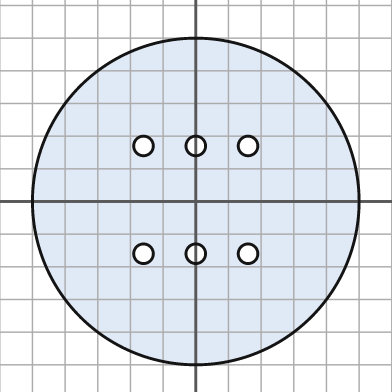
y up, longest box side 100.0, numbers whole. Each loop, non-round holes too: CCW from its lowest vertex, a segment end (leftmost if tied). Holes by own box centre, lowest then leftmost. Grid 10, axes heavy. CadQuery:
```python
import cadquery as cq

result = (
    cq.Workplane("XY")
    .moveTo(0.0, 0.0)
    .circle(50.0)
    .moveTo(-16.0, -16.0)
    .circle(3.0)
    .moveTo(0.0, -16.0)
    .circle(3.0)
    .moveTo(16.0, -16.0)
    .circle(3.0)
    .moveTo(-16.0, 17.0)
    .circle(3.0)
    .moveTo(0.0, 17.0)
    .circle(3.0)
    .moveTo(16.0, 17.0)
    .circle(3.0)
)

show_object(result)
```